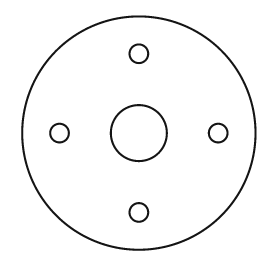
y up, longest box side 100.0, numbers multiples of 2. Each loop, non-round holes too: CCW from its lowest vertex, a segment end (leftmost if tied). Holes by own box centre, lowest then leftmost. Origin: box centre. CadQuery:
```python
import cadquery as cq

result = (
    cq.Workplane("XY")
    .moveTo(0.0, 0.0)
    .circle(50.0)
    .moveTo(0.0, -34.0)
    .circle(4.0)
    .moveTo(-34.0, 0.0)
    .circle(4.0)
    .moveTo(0.0, 0.0)
    .circle(12.0)
    .moveTo(34.0, 0.0)
    .circle(4.0)
    .moveTo(0.0, 34.0)
    .circle(4.0)
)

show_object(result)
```